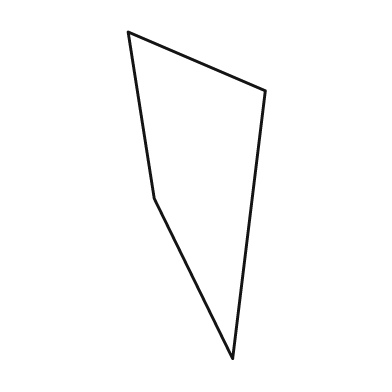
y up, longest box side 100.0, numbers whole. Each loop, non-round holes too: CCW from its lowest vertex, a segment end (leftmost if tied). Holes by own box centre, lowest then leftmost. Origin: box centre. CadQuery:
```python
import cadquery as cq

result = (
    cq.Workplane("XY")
    .moveTo(11.0, -50.0)
    .lineTo(21.0, 32.0)
    .lineTo(-21.0, 50.0)
    .lineTo(-13.0, -1.0)
    .close()
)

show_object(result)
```